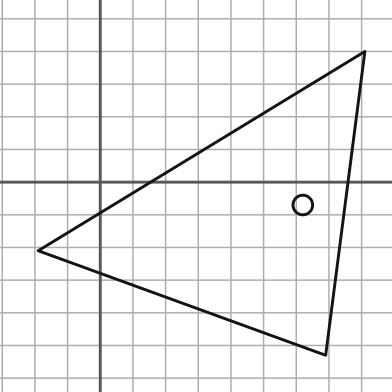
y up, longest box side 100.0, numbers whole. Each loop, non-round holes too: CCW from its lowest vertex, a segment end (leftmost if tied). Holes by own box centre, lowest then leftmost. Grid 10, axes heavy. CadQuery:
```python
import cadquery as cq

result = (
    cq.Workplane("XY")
    .moveTo(69.0, -53.0)
    .lineTo(81.0, 40.0)
    .lineTo(-19.0, -21.0)
    .close()
    .moveTo(62.0, -7.0)
    .circle(3.0)
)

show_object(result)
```